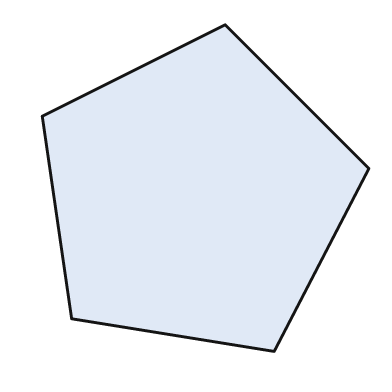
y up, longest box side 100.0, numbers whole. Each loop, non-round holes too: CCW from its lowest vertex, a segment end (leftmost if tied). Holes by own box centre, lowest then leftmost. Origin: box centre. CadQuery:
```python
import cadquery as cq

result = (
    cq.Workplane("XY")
    .moveTo(21.0, -50.0)
    .lineTo(50.0, 6.0)
    .lineTo(6.0, 50.0)
    .lineTo(-50.0, 22.0)
    .lineTo(-41.0, -40.0)
    .close()
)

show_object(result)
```